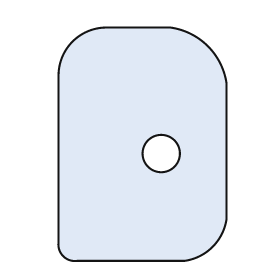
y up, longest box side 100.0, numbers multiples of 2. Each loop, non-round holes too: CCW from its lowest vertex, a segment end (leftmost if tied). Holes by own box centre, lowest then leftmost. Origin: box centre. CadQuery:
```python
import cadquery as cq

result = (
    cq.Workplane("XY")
    .moveTo(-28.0, -50.0)
    .lineTo(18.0, -50.0)
    .threePointArc((30.0, -44.0), (36.0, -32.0))
    .lineTo(36.0, 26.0)
    .threePointArc((28.0, 42.0), (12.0, 50.0))
    .lineTo(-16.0, 50.0)
    .threePointArc((-30.0, 44.0), (-36.0, 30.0))
    .lineTo(-36.0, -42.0)
    .threePointArc((-34.0, -48.0), (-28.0, -50.0))
    .close()
    .moveTo(8.0, -4.0)
    .circle(8.0)
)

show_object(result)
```